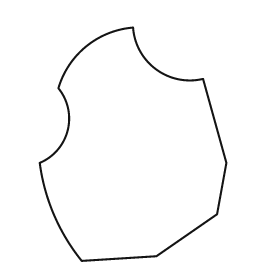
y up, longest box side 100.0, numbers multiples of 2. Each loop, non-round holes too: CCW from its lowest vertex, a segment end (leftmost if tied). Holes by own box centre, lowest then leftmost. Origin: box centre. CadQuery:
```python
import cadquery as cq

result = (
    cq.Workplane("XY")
    .moveTo(-22.0, -50.0)
    .lineTo(10.0, -48.0)
    .lineTo(36.0, -30.0)
    .lineTo(40.0, -8.0)
    .lineTo(30.0, 28.0)
    .threePointArc((10.0, 32.0), (0.0, 50.0))
    .threePointArc((-20.0, 42.0), (-32.0, 24.0))
    .threePointArc((-28.0, 6.0), (-40.0, -8.0))
    .threePointArc((-34.0, -30.0), (-22.0, -50.0))
    .close()
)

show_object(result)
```